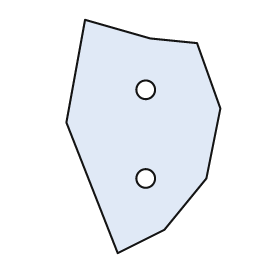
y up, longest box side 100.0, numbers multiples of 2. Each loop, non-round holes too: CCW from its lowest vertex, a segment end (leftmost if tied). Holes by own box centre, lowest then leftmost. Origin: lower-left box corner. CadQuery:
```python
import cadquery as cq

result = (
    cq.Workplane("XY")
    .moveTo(22.0, 0.0)
    .lineTo(42.0, 10.0)
    .lineTo(60.0, 32.0)
    .lineTo(66.0, 62.0)
    .lineTo(56.0, 90.0)
    .lineTo(36.0, 92.0)
    .lineTo(8.0, 100.0)
    .lineTo(0.0, 56.0)
    .close()
    .moveTo(34.0, 32.0)
    .circle(4.0)
    .moveTo(34.0, 70.0)
    .circle(4.0)
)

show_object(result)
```